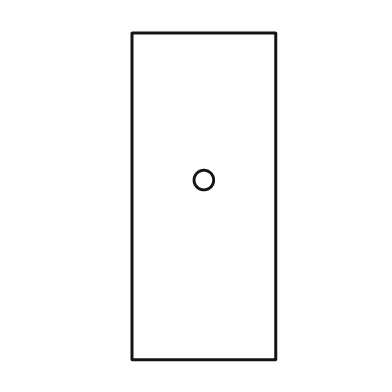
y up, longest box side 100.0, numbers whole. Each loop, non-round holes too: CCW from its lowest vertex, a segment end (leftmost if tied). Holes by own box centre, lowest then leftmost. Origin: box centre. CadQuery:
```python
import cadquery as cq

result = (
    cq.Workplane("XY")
    .moveTo(-22.0, -50.0)
    .lineTo(22.0, -50.0)
    .lineTo(22.0, 50.0)
    .lineTo(-22.0, 50.0)
    .close()
    .moveTo(0.0, 5.0)
    .circle(3.0)
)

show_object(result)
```